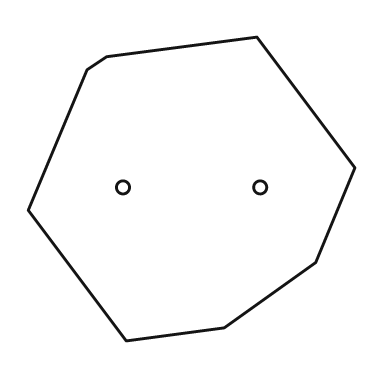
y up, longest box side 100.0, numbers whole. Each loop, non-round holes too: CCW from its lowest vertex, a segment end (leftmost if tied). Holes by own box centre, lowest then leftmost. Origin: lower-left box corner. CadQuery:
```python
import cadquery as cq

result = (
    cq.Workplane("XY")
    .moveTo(30.0, 0.0)
    .lineTo(60.0, 4.0)
    .lineTo(88.0, 24.0)
    .lineTo(100.0, 53.0)
    .lineTo(70.0, 93.0)
    .lineTo(24.0, 87.0)
    .lineTo(18.0, 83.0)
    .lineTo(0.0, 40.0)
    .close()
    .moveTo(29.0, 47.0)
    .circle(2.0)
    .moveTo(71.0, 47.0)
    .circle(2.0)
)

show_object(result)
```